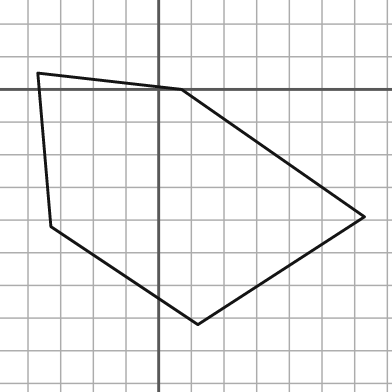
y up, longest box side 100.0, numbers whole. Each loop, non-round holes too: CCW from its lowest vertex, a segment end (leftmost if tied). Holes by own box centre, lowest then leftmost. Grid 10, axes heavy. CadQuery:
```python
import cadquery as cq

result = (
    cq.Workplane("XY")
    .moveTo(12.0, -72.0)
    .lineTo(63.0, -39.0)
    .lineTo(7.0, 0.0)
    .lineTo(-37.0, 5.0)
    .lineTo(-33.0, -42.0)
    .close()
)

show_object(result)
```